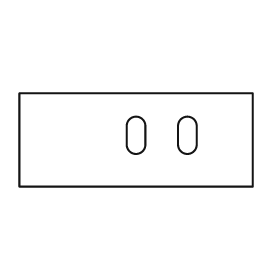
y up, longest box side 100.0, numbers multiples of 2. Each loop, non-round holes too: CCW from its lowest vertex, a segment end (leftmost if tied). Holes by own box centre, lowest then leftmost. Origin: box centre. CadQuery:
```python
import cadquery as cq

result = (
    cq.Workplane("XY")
    .moveTo(-50.0, -20.0)
    .lineTo(50.0, -20.0)
    .lineTo(50.0, 20.0)
    .lineTo(-50.0, 20.0)
    .close()
    .moveTo(-4.0, -2.0)
    .threePointArc((0.0, -6.0), (4.0, -2.0))
    .lineTo(4.0, 6.0)
    .threePointArc((0.0, 10.0), (-4.0, 6.0))
    .close()
    .moveTo(18.0, -2.0)
    .threePointArc((22.0, -6.0), (26.0, -2.0))
    .lineTo(26.0, 6.0)
    .threePointArc((22.0, 10.0), (18.0, 6.0))
    .close()
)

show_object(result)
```